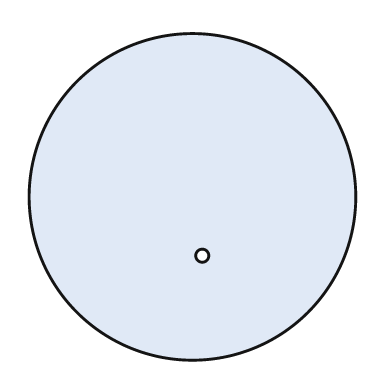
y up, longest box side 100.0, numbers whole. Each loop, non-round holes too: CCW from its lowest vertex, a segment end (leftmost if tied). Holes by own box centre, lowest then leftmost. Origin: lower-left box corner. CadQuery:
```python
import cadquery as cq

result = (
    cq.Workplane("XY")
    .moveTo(50.0, 50.0)
    .circle(50.0)
    .moveTo(53.0, 32.0)
    .circle(2.0)
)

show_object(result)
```